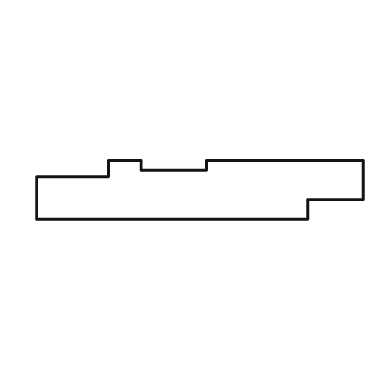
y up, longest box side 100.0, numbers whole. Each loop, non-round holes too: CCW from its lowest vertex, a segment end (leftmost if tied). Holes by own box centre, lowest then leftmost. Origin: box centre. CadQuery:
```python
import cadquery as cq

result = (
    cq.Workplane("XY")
    .moveTo(-50.0, -9.0)
    .lineTo(33.0, -9.0)
    .lineTo(33.0, -3.0)
    .lineTo(50.0, -3.0)
    .lineTo(50.0, 9.0)
    .lineTo(2.0, 9.0)
    .lineTo(2.0, 6.0)
    .lineTo(-18.0, 6.0)
    .lineTo(-18.0, 9.0)
    .lineTo(-28.0, 9.0)
    .lineTo(-28.0, 4.0)
    .lineTo(-50.0, 4.0)
    .close()
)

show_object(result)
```